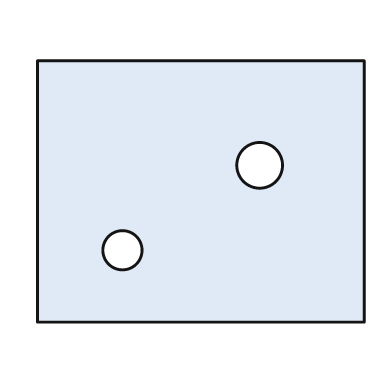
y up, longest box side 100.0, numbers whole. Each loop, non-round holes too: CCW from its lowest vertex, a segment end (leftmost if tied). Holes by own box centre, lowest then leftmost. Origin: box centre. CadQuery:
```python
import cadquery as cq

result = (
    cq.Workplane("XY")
    .moveTo(-50.0, -40.0)
    .lineTo(50.0, -40.0)
    .lineTo(50.0, 40.0)
    .lineTo(-50.0, 40.0)
    .close()
    .moveTo(-24.0, -18.0)
    .circle(6.0)
    .moveTo(18.0, 8.0)
    .circle(7.0)
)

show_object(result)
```